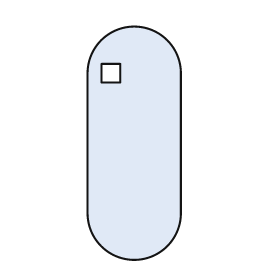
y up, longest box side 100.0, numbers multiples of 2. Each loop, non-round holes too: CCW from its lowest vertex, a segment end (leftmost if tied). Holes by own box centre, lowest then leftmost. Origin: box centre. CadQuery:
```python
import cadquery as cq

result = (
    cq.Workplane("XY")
    .moveTo(-20.0, -30.0)
    .threePointArc((0.0, -50.0), (20.0, -30.0))
    .lineTo(20.0, 30.0)
    .threePointArc((0.0, 50.0), (-20.0, 30.0))
    .close()
    .moveTo(-14.0, 26.0)
    .lineTo(-6.0, 26.0)
    .lineTo(-6.0, 34.0)
    .lineTo(-14.0, 34.0)
    .close()
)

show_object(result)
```